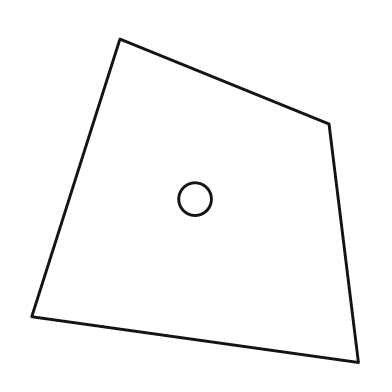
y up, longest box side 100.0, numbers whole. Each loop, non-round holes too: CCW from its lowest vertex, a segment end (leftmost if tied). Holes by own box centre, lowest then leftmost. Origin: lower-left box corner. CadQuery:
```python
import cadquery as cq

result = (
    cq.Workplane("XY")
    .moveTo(100.0, 0.0)
    .lineTo(91.0, 73.0)
    .lineTo(27.0, 99.0)
    .lineTo(0.0, 14.0)
    .close()
    .moveTo(50.0, 50.0)
    .circle(5.0)
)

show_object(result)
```